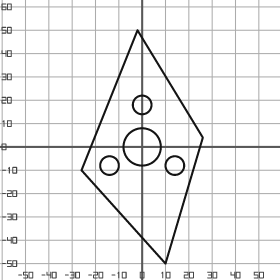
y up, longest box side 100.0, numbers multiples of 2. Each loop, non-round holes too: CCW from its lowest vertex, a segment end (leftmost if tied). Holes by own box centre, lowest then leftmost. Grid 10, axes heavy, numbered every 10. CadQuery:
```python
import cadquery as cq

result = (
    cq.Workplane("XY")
    .moveTo(10.0, -50.0)
    .lineTo(26.0, 4.0)
    .lineTo(-2.0, 50.0)
    .lineTo(-26.0, -10.0)
    .close()
    .moveTo(-14.0, -8.0)
    .circle(4.0)
    .moveTo(14.0, -8.0)
    .circle(4.0)
    .moveTo(0.0, 0.0)
    .circle(8.0)
    .moveTo(0.0, 18.0)
    .circle(4.0)
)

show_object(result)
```